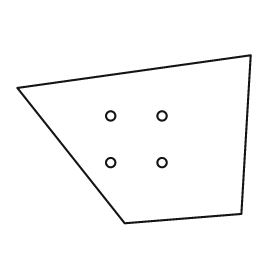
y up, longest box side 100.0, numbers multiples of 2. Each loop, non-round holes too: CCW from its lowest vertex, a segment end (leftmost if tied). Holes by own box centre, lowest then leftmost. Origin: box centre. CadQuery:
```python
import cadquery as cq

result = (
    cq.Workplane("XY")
    .moveTo(-4.0, -36.0)
    .lineTo(46.0, -32.0)
    .lineTo(50.0, 36.0)
    .lineTo(-50.0, 22.0)
    .close()
    .moveTo(-10.0, -10.0)
    .circle(2.0)
    .moveTo(12.0, -10.0)
    .circle(2.0)
    .moveTo(-10.0, 10.0)
    .circle(2.0)
    .moveTo(12.0, 10.0)
    .circle(2.0)
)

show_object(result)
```